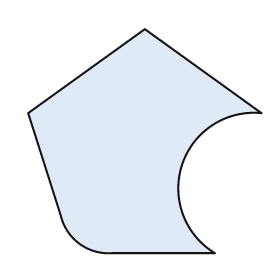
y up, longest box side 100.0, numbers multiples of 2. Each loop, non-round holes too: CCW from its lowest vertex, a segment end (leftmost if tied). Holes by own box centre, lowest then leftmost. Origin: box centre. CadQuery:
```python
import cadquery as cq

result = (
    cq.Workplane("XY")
    .moveTo(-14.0, -48.0)
    .lineTo(30.0, -48.0)
    .threePointArc((16.0, -10.0), (50.0, 12.0))
    .lineTo(0.0, 48.0)
    .lineTo(-50.0, 12.0)
    .lineTo(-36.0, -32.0)
    .threePointArc((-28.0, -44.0), (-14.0, -48.0))
    .close()
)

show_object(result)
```